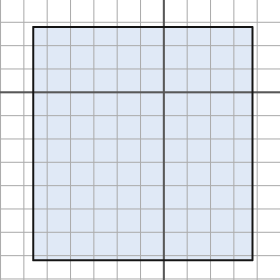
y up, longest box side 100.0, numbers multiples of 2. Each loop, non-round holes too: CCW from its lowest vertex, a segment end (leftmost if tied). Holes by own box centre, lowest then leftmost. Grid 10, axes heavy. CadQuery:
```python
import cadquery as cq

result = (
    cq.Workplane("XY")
    .moveTo(-56.0, -72.0)
    .lineTo(38.0, -72.0)
    .lineTo(38.0, 28.0)
    .lineTo(-56.0, 28.0)
    .close()
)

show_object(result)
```